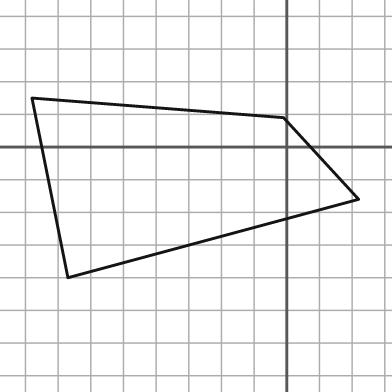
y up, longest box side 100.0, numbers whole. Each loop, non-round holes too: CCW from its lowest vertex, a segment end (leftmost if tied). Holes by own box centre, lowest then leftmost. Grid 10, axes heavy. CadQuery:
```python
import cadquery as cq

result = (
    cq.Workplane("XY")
    .moveTo(-67.0, -40.0)
    .lineTo(22.0, -16.0)
    .lineTo(-1.0, 9.0)
    .lineTo(-78.0, 15.0)
    .close()
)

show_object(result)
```